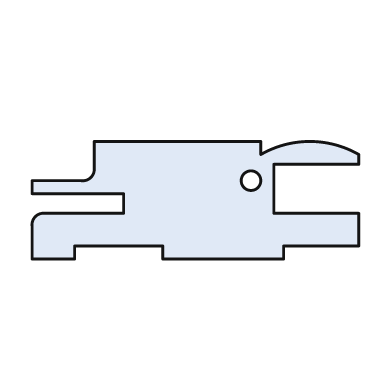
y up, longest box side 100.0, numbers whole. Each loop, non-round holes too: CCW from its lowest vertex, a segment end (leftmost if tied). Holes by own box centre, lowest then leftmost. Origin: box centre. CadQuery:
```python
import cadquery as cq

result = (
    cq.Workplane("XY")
    .moveTo(-50.0, -18.0)
    .lineTo(-37.0, -18.0)
    .lineTo(-37.0, -14.0)
    .lineTo(-10.0, -14.0)
    .lineTo(-10.0, -18.0)
    .lineTo(27.0, -18.0)
    .lineTo(27.0, -14.0)
    .lineTo(50.0, -14.0)
    .lineTo(50.0, -4.0)
    .lineTo(24.0, -4.0)
    .lineTo(24.0, 11.0)
    .lineTo(50.0, 11.0)
    .lineTo(50.0, 14.0)
    .threePointArc((35.0, 18.0), (20.0, 14.0))
    .lineTo(20.0, 18.0)
    .lineTo(-31.0, 18.0)
    .lineTo(-31.0, 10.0)
    .threePointArc((-32.0, 7.0), (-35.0, 6.0))
    .lineTo(-50.0, 6.0)
    .lineTo(-50.0, 2.0)
    .lineTo(-22.0, 2.0)
    .lineTo(-22.0, -4.0)
    .lineTo(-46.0, -4.0)
    .threePointArc((-49.0, -5.0), (-50.0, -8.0))
    .close()
    .moveTo(17.0, 6.0)
    .circle(3.0)
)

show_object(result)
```